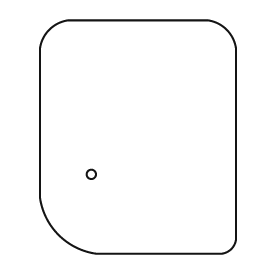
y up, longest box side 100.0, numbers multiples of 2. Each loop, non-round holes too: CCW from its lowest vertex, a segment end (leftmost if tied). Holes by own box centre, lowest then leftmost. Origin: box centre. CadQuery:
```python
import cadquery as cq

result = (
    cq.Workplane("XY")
    .moveTo(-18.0, -50.0)
    .lineTo(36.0, -50.0)
    .threePointArc((40.0, -48.0), (42.0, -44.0))
    .lineTo(42.0, 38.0)
    .threePointArc((38.0, 46.0), (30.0, 50.0))
    .lineTo(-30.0, 50.0)
    .threePointArc((-38.0, 46.0), (-42.0, 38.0))
    .lineTo(-42.0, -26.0)
    .threePointArc((-34.0, -42.0), (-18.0, -50.0))
    .close()
    .moveTo(-20.0, -16.0)
    .circle(2.0)
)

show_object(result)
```